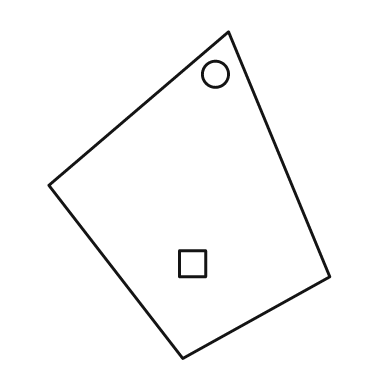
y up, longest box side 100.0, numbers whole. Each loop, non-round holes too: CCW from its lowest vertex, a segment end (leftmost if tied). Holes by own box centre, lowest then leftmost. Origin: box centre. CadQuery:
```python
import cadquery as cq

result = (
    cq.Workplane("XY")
    .moveTo(-2.0, -50.0)
    .lineTo(43.0, -25.0)
    .lineTo(12.0, 50.0)
    .lineTo(-43.0, 3.0)
    .close()
    .moveTo(-3.0, -25.0)
    .lineTo(5.0, -25.0)
    .lineTo(5.0, -17.0)
    .lineTo(-3.0, -17.0)
    .close()
    .moveTo(8.0, 37.0)
    .circle(4.0)
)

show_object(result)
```